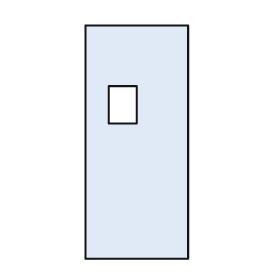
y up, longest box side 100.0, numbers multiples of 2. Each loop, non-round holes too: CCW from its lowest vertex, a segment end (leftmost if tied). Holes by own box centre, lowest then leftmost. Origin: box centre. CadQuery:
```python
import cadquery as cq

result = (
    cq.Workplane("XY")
    .moveTo(-22.0, -50.0)
    .lineTo(22.0, -50.0)
    .lineTo(22.0, 50.0)
    .lineTo(-22.0, 50.0)
    .close()
    .moveTo(-12.0, 8.0)
    .lineTo(0.0, 8.0)
    .lineTo(0.0, 24.0)
    .lineTo(-12.0, 24.0)
    .close()
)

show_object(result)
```